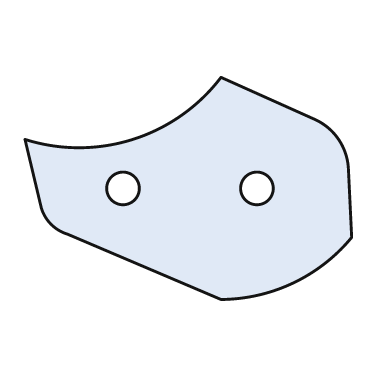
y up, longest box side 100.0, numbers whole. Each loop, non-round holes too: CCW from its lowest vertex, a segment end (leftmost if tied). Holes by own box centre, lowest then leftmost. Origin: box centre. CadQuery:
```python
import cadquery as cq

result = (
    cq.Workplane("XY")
    .moveTo(10.0, -34.0)
    .threePointArc((32.0, -29.0), (50.0, -15.0))
    .lineTo(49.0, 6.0)
    .threePointArc((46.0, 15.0), (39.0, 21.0))
    .lineTo(10.0, 34.0)
    .threePointArc((-17.0, 15.0), (-50.0, 15.0))
    .lineTo(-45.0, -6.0)
    .threePointArc((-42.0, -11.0), (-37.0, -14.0))
    .close()
    .moveTo(-20.0, 0.0)
    .circle(5.0)
    .moveTo(21.0, 0.0)
    .circle(5.0)
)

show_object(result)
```